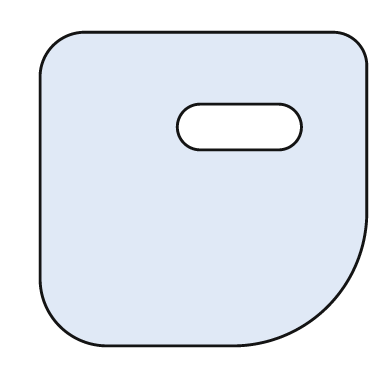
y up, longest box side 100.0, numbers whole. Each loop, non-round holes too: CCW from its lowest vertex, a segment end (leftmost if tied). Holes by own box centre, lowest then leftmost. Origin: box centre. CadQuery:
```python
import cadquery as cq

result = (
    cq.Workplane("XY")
    .moveTo(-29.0, -48.0)
    .lineTo(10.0, -48.0)
    .threePointArc((38.0, -36.0), (50.0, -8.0))
    .lineTo(50.0, 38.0)
    .threePointArc((47.0, 45.0), (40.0, 48.0))
    .lineTo(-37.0, 48.0)
    .threePointArc((-46.0, 44.0), (-50.0, 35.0))
    .lineTo(-50.0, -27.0)
    .threePointArc((-44.0, -42.0), (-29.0, -48.0))
    .close()
    .moveTo(-1.0, 12.0)
    .lineTo(23.0, 12.0)
    .threePointArc((30.0, 19.0), (23.0, 26.0))
    .lineTo(-1.0, 26.0)
    .threePointArc((-8.0, 19.0), (-1.0, 12.0))
    .close()
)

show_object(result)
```